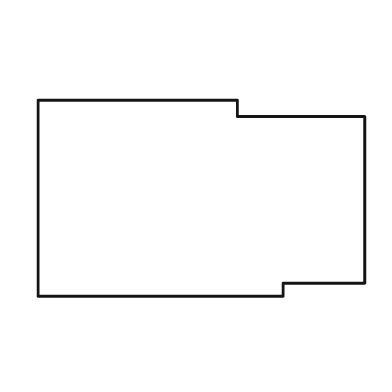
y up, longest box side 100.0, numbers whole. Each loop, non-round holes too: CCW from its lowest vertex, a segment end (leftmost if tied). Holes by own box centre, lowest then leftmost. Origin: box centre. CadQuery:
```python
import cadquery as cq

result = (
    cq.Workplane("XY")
    .moveTo(-50.0, -30.0)
    .lineTo(25.0, -30.0)
    .lineTo(25.0, -26.0)
    .lineTo(50.0, -26.0)
    .lineTo(50.0, 25.0)
    .lineTo(11.0, 25.0)
    .lineTo(11.0, 30.0)
    .lineTo(-50.0, 30.0)
    .close()
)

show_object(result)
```